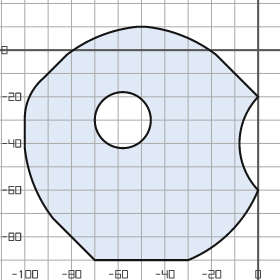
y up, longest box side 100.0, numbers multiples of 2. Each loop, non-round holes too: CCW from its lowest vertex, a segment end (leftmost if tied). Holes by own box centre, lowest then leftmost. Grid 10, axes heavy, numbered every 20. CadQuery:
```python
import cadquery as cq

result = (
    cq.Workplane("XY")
    .moveTo(-70.0, -90.0)
    .lineTo(-30.0, -90.0)
    .threePointArc((-12.0, -78.0), (0.0, -60.0))
    .threePointArc((-8.0, -40.0), (0.0, -20.0))
    .lineTo(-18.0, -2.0)
    .threePointArc((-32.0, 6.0), (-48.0, 10.0))
    .lineTo(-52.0, 10.0)
    .threePointArc((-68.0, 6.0), (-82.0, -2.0))
    .lineTo(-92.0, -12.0)
    .threePointArc((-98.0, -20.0), (-100.0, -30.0))
    .lineTo(-100.0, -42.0)
    .threePointArc((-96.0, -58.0), (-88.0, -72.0))
    .close()
    .moveTo(-58.0, -30.0)
    .circle(12.0)
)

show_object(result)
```